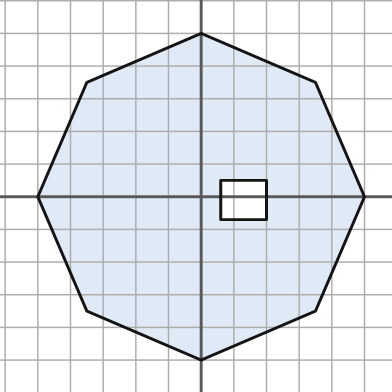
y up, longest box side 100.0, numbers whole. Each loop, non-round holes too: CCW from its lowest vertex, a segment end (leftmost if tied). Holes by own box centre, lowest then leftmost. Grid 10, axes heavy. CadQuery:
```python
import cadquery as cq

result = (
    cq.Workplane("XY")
    .moveTo(0.0, -50.0)
    .lineTo(35.0, -35.0)
    .lineTo(50.0, 0.0)
    .lineTo(35.0, 35.0)
    .lineTo(0.0, 50.0)
    .lineTo(-35.0, 35.0)
    .lineTo(-50.0, 0.0)
    .lineTo(-35.0, -35.0)
    .close()
    .moveTo(6.0, -7.0)
    .lineTo(20.0, -7.0)
    .lineTo(20.0, 5.0)
    .lineTo(6.0, 5.0)
    .close()
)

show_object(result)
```